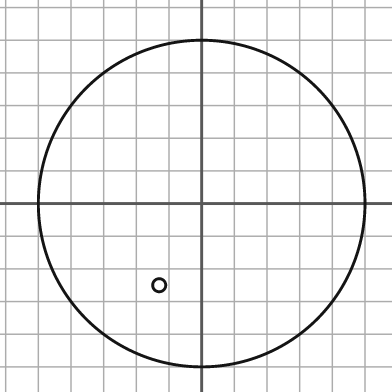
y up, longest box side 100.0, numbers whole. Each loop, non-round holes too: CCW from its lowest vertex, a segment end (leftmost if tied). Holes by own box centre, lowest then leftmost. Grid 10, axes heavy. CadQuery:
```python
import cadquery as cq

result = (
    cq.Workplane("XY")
    .moveTo(0.0, 0.0)
    .circle(50.0)
    .moveTo(-13.0, -25.0)
    .circle(2.0)
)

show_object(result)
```